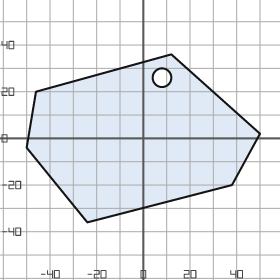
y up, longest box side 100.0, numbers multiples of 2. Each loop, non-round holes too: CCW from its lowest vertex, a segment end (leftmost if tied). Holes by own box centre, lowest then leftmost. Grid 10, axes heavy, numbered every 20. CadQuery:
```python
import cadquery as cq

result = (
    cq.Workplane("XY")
    .moveTo(-24.0, -36.0)
    .lineTo(38.0, -20.0)
    .lineTo(50.0, 2.0)
    .lineTo(12.0, 36.0)
    .lineTo(-46.0, 20.0)
    .lineTo(-50.0, -4.0)
    .close()
    .moveTo(8.0, 26.0)
    .circle(4.0)
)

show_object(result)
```